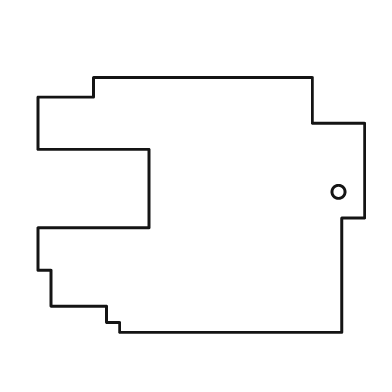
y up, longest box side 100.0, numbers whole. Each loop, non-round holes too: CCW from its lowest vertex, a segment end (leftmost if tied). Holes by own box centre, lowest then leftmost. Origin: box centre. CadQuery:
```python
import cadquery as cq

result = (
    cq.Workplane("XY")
    .moveTo(-25.0, -39.0)
    .lineTo(43.0, -39.0)
    .lineTo(43.0, -4.0)
    .lineTo(50.0, -4.0)
    .lineTo(50.0, 25.0)
    .lineTo(34.0, 25.0)
    .lineTo(34.0, 39.0)
    .lineTo(-33.0, 39.0)
    .lineTo(-33.0, 33.0)
    .lineTo(-50.0, 33.0)
    .lineTo(-50.0, 17.0)
    .lineTo(-16.0, 17.0)
    .lineTo(-16.0, -7.0)
    .lineTo(-50.0, -7.0)
    .lineTo(-50.0, -20.0)
    .lineTo(-46.0, -20.0)
    .lineTo(-46.0, -31.0)
    .lineTo(-29.0, -31.0)
    .lineTo(-29.0, -36.0)
    .lineTo(-25.0, -36.0)
    .close()
    .moveTo(42.0, 4.0)
    .circle(2.0)
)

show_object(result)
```